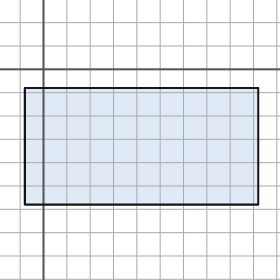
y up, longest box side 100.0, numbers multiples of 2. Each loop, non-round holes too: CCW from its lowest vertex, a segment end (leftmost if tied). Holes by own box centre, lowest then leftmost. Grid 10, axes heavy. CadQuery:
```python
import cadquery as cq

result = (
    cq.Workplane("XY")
    .moveTo(-8.0, -58.0)
    .lineTo(92.0, -58.0)
    .lineTo(92.0, -8.0)
    .lineTo(-8.0, -8.0)
    .close()
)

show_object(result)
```